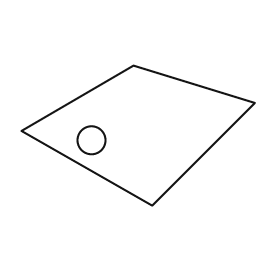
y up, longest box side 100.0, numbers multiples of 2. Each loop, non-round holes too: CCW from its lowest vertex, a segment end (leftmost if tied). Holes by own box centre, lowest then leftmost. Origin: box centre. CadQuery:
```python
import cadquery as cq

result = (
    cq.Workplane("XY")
    .moveTo(6.0, -30.0)
    .lineTo(50.0, 14.0)
    .lineTo(-2.0, 30.0)
    .lineTo(-50.0, 2.0)
    .close()
    .moveTo(-20.0, -2.0)
    .circle(6.0)
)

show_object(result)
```